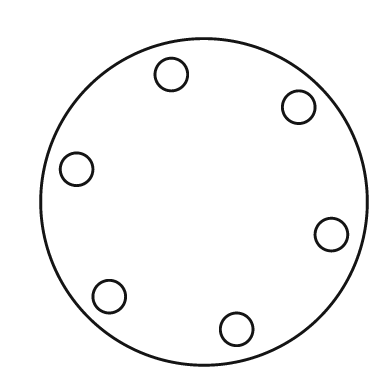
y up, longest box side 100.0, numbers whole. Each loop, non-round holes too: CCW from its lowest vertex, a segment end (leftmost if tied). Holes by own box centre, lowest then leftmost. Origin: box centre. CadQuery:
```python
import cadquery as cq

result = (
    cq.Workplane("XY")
    .moveTo(0.0, 0.0)
    .circle(50.0)
    .moveTo(10.0, -39.0)
    .circle(5.0)
    .moveTo(-29.0, -29.0)
    .circle(5.0)
    .moveTo(39.0, -10.0)
    .circle(5.0)
    .moveTo(-39.0, 10.0)
    .circle(5.0)
    .moveTo(29.0, 29.0)
    .circle(5.0)
    .moveTo(-10.0, 39.0)
    .circle(5.0)
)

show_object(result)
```